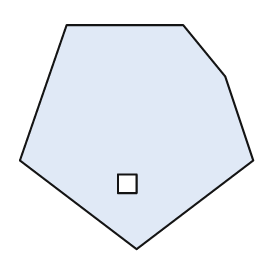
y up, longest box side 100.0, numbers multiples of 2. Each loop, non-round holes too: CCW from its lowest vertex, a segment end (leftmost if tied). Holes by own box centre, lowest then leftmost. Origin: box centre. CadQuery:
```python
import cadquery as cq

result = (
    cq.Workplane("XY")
    .moveTo(0.0, -48.0)
    .lineTo(50.0, -10.0)
    .lineTo(38.0, 26.0)
    .lineTo(20.0, 48.0)
    .lineTo(-30.0, 48.0)
    .lineTo(-50.0, -10.0)
    .close()
    .moveTo(-8.0, -24.0)
    .lineTo(0.0, -24.0)
    .lineTo(0.0, -16.0)
    .lineTo(-8.0, -16.0)
    .close()
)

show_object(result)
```